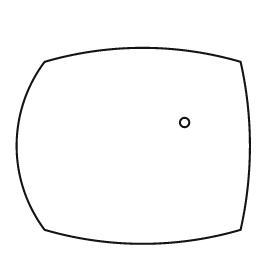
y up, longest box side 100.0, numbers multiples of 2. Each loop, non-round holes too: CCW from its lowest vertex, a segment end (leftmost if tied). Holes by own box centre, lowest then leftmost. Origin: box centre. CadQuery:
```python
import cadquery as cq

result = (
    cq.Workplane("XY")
    .moveTo(-38.0, -36.0)
    .threePointArc((4.0, -42.0), (46.0, -36.0))
    .threePointArc((50.0, 0.0), (46.0, 36.0))
    .threePointArc((4.0, 42.0), (-38.0, 36.0))
    .threePointArc((-50.0, 0.0), (-38.0, -36.0))
    .close()
    .moveTo(22.0, 10.0)
    .circle(2.0)
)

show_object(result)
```